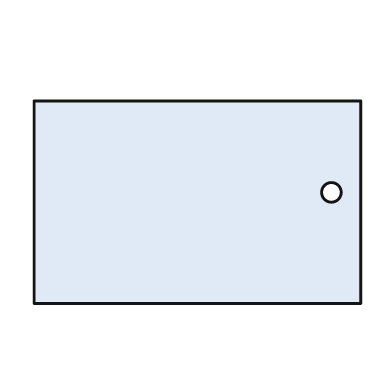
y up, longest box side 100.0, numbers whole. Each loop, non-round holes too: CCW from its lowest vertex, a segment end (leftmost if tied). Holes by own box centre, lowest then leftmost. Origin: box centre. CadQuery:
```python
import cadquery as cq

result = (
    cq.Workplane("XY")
    .moveTo(-50.0, -31.0)
    .lineTo(50.0, -31.0)
    .lineTo(50.0, 31.0)
    .lineTo(-50.0, 31.0)
    .close()
    .moveTo(41.0, 3.0)
    .circle(3.0)
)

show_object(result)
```